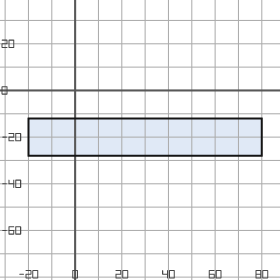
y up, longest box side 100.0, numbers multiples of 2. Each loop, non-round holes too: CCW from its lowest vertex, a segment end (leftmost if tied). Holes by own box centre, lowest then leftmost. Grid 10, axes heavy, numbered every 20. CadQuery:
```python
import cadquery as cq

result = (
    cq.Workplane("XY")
    .moveTo(-20.0, -28.0)
    .lineTo(80.0, -28.0)
    .lineTo(80.0, -12.0)
    .lineTo(-20.0, -12.0)
    .close()
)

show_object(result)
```